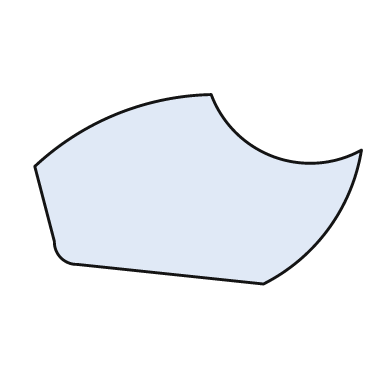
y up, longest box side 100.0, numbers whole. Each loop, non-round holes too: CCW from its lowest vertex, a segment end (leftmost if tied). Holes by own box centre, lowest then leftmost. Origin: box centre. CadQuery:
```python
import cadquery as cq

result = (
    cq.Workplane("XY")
    .moveTo(20.0, -29.0)
    .threePointArc((40.0, -12.0), (50.0, 12.0))
    .threePointArc((23.0, 10.0), (4.0, 29.0))
    .threePointArc((-25.0, 23.0), (-50.0, 7.0))
    .lineTo(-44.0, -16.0)
    .threePointArc((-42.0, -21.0), (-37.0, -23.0))
    .close()
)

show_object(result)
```